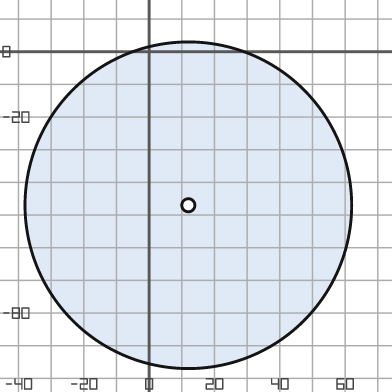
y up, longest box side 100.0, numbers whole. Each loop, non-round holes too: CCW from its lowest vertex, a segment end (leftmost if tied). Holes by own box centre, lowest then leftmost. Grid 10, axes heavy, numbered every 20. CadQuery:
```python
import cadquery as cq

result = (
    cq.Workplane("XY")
    .moveTo(12.0, -47.0)
    .circle(50.0)
    .moveTo(12.0, -47.0)
    .circle(2.0)
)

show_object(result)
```